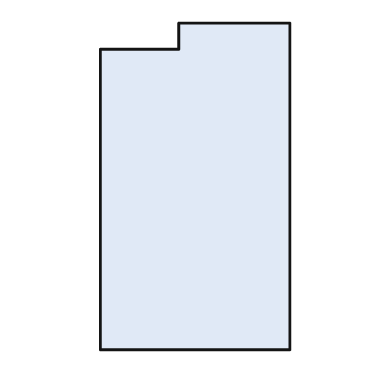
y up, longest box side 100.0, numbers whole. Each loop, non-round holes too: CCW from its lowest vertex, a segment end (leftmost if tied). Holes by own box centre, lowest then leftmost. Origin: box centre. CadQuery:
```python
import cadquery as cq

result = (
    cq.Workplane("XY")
    .moveTo(-29.0, -50.0)
    .lineTo(29.0, -50.0)
    .lineTo(29.0, 50.0)
    .lineTo(-5.0, 50.0)
    .lineTo(-5.0, 42.0)
    .lineTo(-29.0, 42.0)
    .close()
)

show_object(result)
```